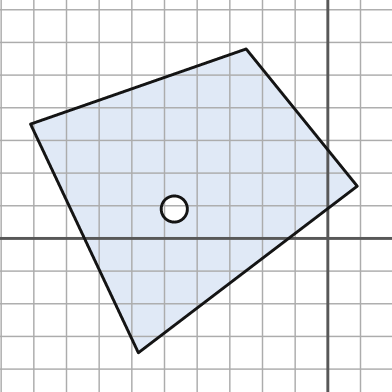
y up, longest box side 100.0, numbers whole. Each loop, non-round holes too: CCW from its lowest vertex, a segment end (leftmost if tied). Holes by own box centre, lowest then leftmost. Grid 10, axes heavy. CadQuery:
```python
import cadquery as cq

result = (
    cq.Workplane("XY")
    .moveTo(-58.0, -35.0)
    .lineTo(9.0, 16.0)
    .lineTo(-25.0, 58.0)
    .lineTo(-91.0, 35.0)
    .close()
    .moveTo(-47.0, 9.0)
    .circle(4.0)
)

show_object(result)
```